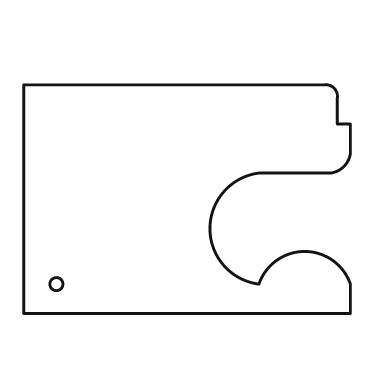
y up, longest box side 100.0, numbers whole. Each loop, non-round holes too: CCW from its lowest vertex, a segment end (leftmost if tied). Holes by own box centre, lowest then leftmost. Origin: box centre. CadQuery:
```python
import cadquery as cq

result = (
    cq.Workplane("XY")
    .moveTo(-50.0, -35.0)
    .lineTo(50.0, -35.0)
    .lineTo(50.0, -26.0)
    .threePointArc((36.0, -16.0), (22.0, -26.0))
    .threePointArc((7.0, -9.0), (22.0, 8.0))
    .lineTo(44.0, 8.0)
    .threePointArc((48.0, 10.0), (50.0, 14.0))
    .lineTo(50.0, 23.0)
    .lineTo(46.0, 23.0)
    .lineTo(46.0, 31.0)
    .threePointArc((45.0, 34.0), (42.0, 35.0))
    .lineTo(-50.0, 35.0)
    .close()
    .moveTo(-40.0, -26.0)
    .circle(2.0)
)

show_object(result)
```